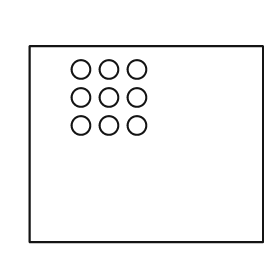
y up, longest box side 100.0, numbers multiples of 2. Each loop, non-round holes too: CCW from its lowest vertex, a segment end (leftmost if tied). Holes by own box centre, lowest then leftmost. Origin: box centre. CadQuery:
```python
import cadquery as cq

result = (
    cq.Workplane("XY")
    .moveTo(-50.0, -42.0)
    .lineTo(50.0, -42.0)
    .lineTo(50.0, 42.0)
    .lineTo(-50.0, 42.0)
    .close()
    .moveTo(-28.0, 8.0)
    .circle(4.0)
    .moveTo(-16.0, 8.0)
    .circle(4.0)
    .moveTo(-4.0, 8.0)
    .circle(4.0)
    .moveTo(-28.0, 20.0)
    .circle(4.0)
    .moveTo(-16.0, 20.0)
    .circle(4.0)
    .moveTo(-4.0, 20.0)
    .circle(4.0)
    .moveTo(-28.0, 32.0)
    .circle(4.0)
    .moveTo(-16.0, 32.0)
    .circle(4.0)
    .moveTo(-4.0, 32.0)
    .circle(4.0)
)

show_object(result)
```